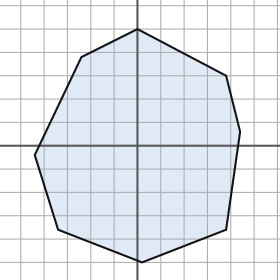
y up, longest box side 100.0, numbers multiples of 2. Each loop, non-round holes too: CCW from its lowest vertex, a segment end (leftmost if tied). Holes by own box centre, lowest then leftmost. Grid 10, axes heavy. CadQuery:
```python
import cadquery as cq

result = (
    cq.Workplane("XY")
    .moveTo(2.0, -50.0)
    .lineTo(38.0, -36.0)
    .lineTo(44.0, 6.0)
    .lineTo(38.0, 30.0)
    .lineTo(0.0, 50.0)
    .lineTo(-24.0, 38.0)
    .lineTo(-44.0, -4.0)
    .lineTo(-34.0, -36.0)
    .close()
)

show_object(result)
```